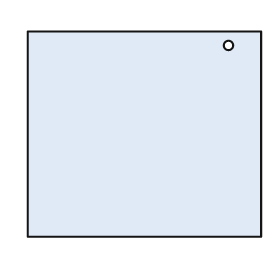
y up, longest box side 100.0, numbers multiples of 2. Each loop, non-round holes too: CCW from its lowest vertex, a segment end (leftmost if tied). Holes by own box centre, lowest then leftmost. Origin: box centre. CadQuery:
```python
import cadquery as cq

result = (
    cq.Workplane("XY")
    .moveTo(-50.0, -44.0)
    .lineTo(50.0, -44.0)
    .lineTo(50.0, 44.0)
    .lineTo(-50.0, 44.0)
    .close()
    .moveTo(36.0, 38.0)
    .circle(2.0)
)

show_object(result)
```